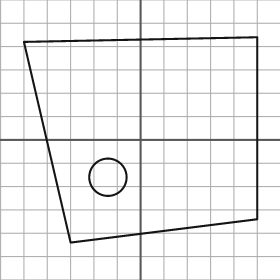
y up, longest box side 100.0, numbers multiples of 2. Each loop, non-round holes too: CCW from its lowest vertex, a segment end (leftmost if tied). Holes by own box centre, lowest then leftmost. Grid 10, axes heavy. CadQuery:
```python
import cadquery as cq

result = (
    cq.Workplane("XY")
    .moveTo(-30.0, -44.0)
    .lineTo(50.0, -34.0)
    .lineTo(50.0, 44.0)
    .lineTo(-50.0, 42.0)
    .close()
    .moveTo(-14.0, -16.0)
    .circle(8.0)
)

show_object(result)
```